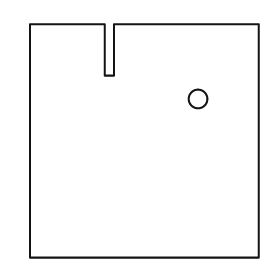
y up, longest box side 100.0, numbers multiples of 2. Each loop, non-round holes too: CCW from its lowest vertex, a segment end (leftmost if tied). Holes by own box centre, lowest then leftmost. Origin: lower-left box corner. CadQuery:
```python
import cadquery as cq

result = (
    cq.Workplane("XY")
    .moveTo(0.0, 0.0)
    .lineTo(98.0, 0.0)
    .lineTo(98.0, 100.0)
    .lineTo(36.0, 100.0)
    .lineTo(36.0, 78.0)
    .lineTo(32.0, 78.0)
    .lineTo(32.0, 100.0)
    .lineTo(0.0, 100.0)
    .close()
    .moveTo(72.0, 68.0)
    .circle(4.0)
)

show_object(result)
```